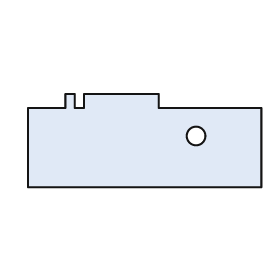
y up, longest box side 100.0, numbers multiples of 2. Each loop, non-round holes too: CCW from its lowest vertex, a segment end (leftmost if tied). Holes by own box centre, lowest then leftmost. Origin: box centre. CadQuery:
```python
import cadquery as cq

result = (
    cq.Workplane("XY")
    .moveTo(-50.0, -20.0)
    .lineTo(50.0, -20.0)
    .lineTo(50.0, 14.0)
    .lineTo(6.0, 14.0)
    .lineTo(6.0, 20.0)
    .lineTo(-26.0, 20.0)
    .lineTo(-26.0, 14.0)
    .lineTo(-30.0, 14.0)
    .lineTo(-30.0, 20.0)
    .lineTo(-34.0, 20.0)
    .lineTo(-34.0, 14.0)
    .lineTo(-50.0, 14.0)
    .close()
    .moveTo(22.0, 2.0)
    .circle(4.0)
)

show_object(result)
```